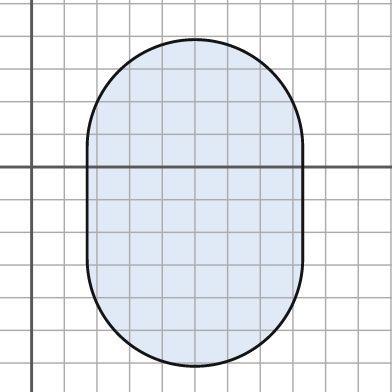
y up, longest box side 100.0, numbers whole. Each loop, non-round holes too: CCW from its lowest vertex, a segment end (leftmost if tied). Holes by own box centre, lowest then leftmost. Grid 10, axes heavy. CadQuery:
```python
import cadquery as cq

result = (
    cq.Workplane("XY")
    .moveTo(17.0, -28.0)
    .threePointArc((50.0, -61.0), (83.0, -28.0))
    .lineTo(83.0, 6.0)
    .threePointArc((50.0, 39.0), (17.0, 6.0))
    .close()
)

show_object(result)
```